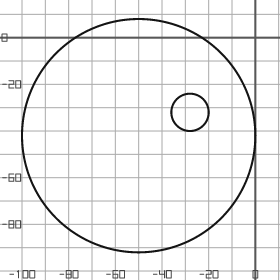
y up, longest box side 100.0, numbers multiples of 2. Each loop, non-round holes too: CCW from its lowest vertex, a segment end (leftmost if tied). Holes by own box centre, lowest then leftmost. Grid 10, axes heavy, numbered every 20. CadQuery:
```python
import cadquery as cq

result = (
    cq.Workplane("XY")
    .moveTo(-50.0, -42.0)
    .circle(50.0)
    .moveTo(-28.0, -32.0)
    .circle(8.0)
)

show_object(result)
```